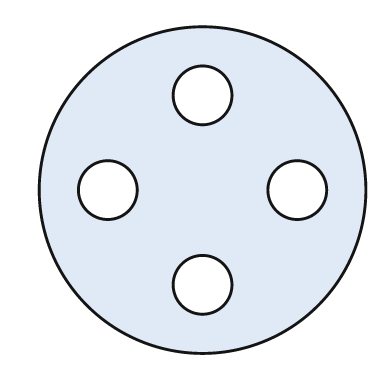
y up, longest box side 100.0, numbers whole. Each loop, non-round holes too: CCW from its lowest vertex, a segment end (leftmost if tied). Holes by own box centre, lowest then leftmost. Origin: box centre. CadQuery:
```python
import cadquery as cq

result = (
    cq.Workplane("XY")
    .moveTo(0.0, 0.0)
    .circle(50.0)
    .moveTo(0.0, -29.0)
    .circle(9.0)
    .moveTo(-29.0, 0.0)
    .circle(9.0)
    .moveTo(29.0, 0.0)
    .circle(9.0)
    .moveTo(0.0, 29.0)
    .circle(9.0)
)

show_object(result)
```